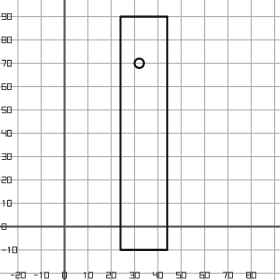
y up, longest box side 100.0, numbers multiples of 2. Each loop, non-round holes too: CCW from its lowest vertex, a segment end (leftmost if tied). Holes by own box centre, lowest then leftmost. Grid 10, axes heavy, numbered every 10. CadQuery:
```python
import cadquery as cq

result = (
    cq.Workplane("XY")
    .moveTo(24.0, -10.0)
    .lineTo(44.0, -10.0)
    .lineTo(44.0, 90.0)
    .lineTo(24.0, 90.0)
    .close()
    .moveTo(32.0, 70.0)
    .circle(2.0)
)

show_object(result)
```